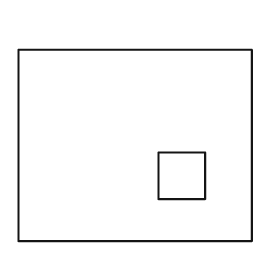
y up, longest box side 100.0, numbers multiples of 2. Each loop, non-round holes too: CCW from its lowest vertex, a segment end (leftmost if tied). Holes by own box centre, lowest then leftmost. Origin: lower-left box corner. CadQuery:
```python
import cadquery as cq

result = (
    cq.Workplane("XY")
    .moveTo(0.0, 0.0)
    .lineTo(100.0, 0.0)
    .lineTo(100.0, 82.0)
    .lineTo(0.0, 82.0)
    .close()
    .moveTo(60.0, 18.0)
    .lineTo(80.0, 18.0)
    .lineTo(80.0, 38.0)
    .lineTo(60.0, 38.0)
    .close()
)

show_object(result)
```